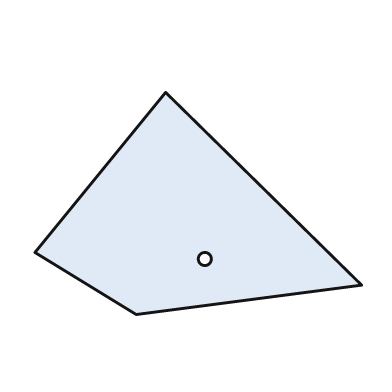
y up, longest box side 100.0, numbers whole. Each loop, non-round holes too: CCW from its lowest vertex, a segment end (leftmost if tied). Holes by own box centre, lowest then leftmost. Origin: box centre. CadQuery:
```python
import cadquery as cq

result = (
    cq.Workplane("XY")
    .moveTo(-19.0, -34.0)
    .lineTo(50.0, -25.0)
    .lineTo(-10.0, 34.0)
    .lineTo(-50.0, -15.0)
    .close()
    .moveTo(2.0, -17.0)
    .circle(2.0)
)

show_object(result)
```